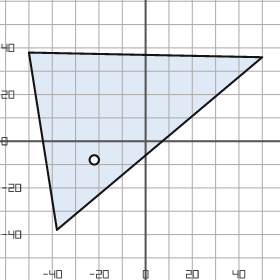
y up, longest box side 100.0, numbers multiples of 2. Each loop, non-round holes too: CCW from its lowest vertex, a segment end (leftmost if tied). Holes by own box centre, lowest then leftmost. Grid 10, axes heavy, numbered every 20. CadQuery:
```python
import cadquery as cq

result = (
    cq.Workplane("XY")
    .moveTo(-38.0, -38.0)
    .lineTo(50.0, 36.0)
    .lineTo(-50.0, 38.0)
    .close()
    .moveTo(-22.0, -8.0)
    .circle(2.0)
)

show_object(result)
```